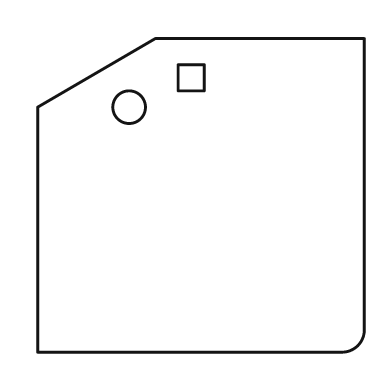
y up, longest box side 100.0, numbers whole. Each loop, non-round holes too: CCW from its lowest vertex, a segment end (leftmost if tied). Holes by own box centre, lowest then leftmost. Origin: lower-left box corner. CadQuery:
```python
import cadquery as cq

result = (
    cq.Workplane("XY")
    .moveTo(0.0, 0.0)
    .lineTo(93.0, 0.0)
    .threePointArc((98.0, 2.0), (100.0, 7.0))
    .lineTo(100.0, 96.0)
    .lineTo(36.0, 96.0)
    .lineTo(0.0, 75.0)
    .close()
    .moveTo(28.0, 75.0)
    .circle(5.0)
    .moveTo(43.0, 80.0)
    .lineTo(51.0, 80.0)
    .lineTo(51.0, 88.0)
    .lineTo(43.0, 88.0)
    .close()
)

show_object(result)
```